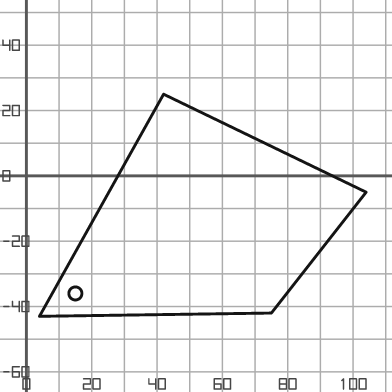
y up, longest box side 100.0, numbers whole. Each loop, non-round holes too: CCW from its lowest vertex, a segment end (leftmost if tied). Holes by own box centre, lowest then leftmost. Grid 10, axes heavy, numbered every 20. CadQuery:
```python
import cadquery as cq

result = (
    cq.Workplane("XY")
    .moveTo(4.0, -43.0)
    .lineTo(75.0, -42.0)
    .lineTo(104.0, -5.0)
    .lineTo(42.0, 25.0)
    .close()
    .moveTo(15.0, -36.0)
    .circle(2.0)
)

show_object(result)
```